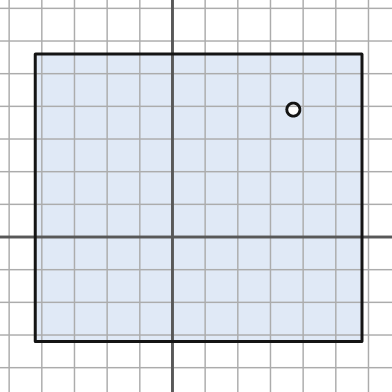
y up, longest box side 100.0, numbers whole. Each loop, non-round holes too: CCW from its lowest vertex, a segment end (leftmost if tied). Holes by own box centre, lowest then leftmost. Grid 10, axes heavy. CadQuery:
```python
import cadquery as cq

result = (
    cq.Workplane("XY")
    .moveTo(-42.0, -32.0)
    .lineTo(58.0, -32.0)
    .lineTo(58.0, 56.0)
    .lineTo(-42.0, 56.0)
    .close()
    .moveTo(37.0, 39.0)
    .circle(2.0)
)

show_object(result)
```